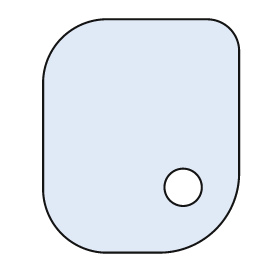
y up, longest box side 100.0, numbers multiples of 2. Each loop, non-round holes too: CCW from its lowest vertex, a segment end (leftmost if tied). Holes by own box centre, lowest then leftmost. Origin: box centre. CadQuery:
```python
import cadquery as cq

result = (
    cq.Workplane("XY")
    .moveTo(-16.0, -50.0)
    .lineTo(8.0, -50.0)
    .threePointArc((32.0, -40.0), (42.0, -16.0))
    .lineTo(42.0, 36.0)
    .threePointArc((38.0, 46.0), (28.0, 50.0))
    .lineTo(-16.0, 50.0)
    .threePointArc((-34.0, 42.0), (-42.0, 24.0))
    .lineTo(-42.0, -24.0)
    .threePointArc((-34.0, -42.0), (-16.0, -50.0))
    .close()
    .moveTo(18.0, -22.0)
    .circle(8.0)
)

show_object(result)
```